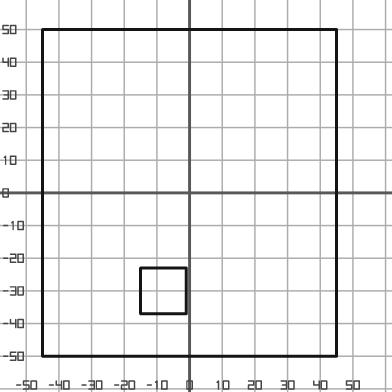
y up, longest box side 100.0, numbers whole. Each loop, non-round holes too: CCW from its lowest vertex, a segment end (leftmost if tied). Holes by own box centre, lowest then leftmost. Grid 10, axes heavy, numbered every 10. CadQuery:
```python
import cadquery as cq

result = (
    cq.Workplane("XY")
    .moveTo(-45.0, -50.0)
    .lineTo(45.0, -50.0)
    .lineTo(45.0, 50.0)
    .lineTo(-45.0, 50.0)
    .close()
    .moveTo(-15.0, -37.0)
    .lineTo(-1.0, -37.0)
    .lineTo(-1.0, -23.0)
    .lineTo(-15.0, -23.0)
    .close()
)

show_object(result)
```